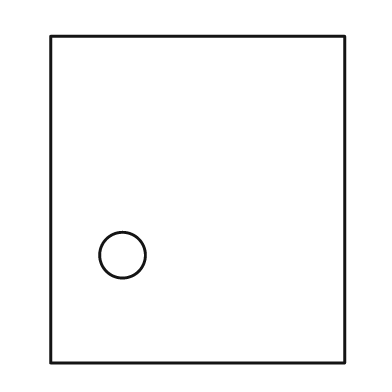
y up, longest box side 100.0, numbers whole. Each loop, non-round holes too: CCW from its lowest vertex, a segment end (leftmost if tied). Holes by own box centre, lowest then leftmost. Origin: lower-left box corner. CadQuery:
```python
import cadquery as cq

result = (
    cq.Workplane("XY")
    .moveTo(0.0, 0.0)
    .lineTo(90.0, 0.0)
    .lineTo(90.0, 100.0)
    .lineTo(0.0, 100.0)
    .close()
    .moveTo(22.0, 33.0)
    .circle(7.0)
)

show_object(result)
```